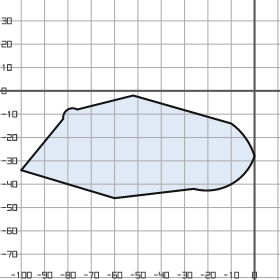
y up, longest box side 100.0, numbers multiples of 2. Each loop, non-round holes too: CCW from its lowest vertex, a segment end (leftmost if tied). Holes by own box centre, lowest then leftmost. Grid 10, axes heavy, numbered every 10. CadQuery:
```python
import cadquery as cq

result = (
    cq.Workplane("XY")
    .moveTo(-60.0, -46.0)
    .lineTo(-26.0, -42.0)
    .threePointArc((-10.0, -40.0), (0.0, -28.0))
    .threePointArc((-4.0, -20.0), (-10.0, -14.0))
    .lineTo(-52.0, -2.0)
    .lineTo(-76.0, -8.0)
    .threePointArc((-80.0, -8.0), (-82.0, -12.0))
    .lineTo(-100.0, -34.0)
    .close()
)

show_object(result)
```